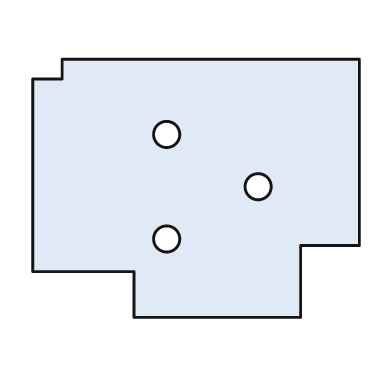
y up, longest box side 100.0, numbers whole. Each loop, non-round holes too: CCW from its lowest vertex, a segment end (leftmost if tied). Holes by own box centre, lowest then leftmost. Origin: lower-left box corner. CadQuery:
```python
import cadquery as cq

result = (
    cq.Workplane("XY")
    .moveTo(31.0, 0.0)
    .lineTo(82.0, 0.0)
    .lineTo(82.0, 22.0)
    .lineTo(100.0, 22.0)
    .lineTo(100.0, 79.0)
    .lineTo(9.0, 79.0)
    .lineTo(9.0, 73.0)
    .lineTo(0.0, 73.0)
    .lineTo(0.0, 14.0)
    .lineTo(31.0, 14.0)
    .close()
    .moveTo(41.0, 24.0)
    .circle(4.0)
    .moveTo(69.0, 40.0)
    .circle(4.0)
    .moveTo(41.0, 56.0)
    .circle(4.0)
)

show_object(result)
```